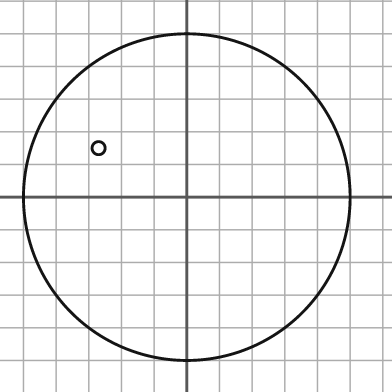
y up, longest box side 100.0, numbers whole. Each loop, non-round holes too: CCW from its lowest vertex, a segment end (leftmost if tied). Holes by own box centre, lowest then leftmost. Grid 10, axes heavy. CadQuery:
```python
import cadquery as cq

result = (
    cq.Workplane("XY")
    .moveTo(0.0, 0.0)
    .circle(50.0)
    .moveTo(-27.0, 15.0)
    .circle(2.0)
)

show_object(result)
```